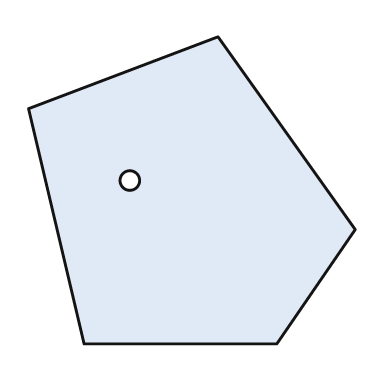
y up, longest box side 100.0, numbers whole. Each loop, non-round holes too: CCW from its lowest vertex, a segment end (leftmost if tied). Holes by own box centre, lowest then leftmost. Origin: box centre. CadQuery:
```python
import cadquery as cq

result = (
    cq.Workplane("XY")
    .moveTo(-33.0, -47.0)
    .lineTo(26.0, -47.0)
    .lineTo(50.0, -12.0)
    .lineTo(8.0, 47.0)
    .lineTo(-50.0, 25.0)
    .close()
    .moveTo(-19.0, 3.0)
    .circle(3.0)
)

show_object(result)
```